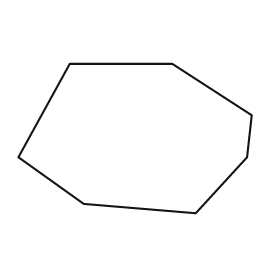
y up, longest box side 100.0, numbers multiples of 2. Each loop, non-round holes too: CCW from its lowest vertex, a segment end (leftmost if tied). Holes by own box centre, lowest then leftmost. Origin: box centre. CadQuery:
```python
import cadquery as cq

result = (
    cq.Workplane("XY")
    .moveTo(26.0, -32.0)
    .lineTo(48.0, -8.0)
    .lineTo(50.0, 10.0)
    .lineTo(16.0, 32.0)
    .lineTo(-28.0, 32.0)
    .lineTo(-50.0, -8.0)
    .lineTo(-22.0, -28.0)
    .close()
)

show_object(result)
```